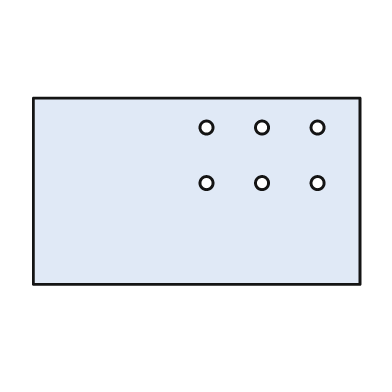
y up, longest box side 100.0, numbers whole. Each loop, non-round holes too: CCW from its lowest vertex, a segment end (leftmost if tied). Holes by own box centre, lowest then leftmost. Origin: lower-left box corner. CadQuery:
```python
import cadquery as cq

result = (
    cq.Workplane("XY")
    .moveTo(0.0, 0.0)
    .lineTo(100.0, 0.0)
    .lineTo(100.0, 57.0)
    .lineTo(0.0, 57.0)
    .close()
    .moveTo(53.0, 31.0)
    .circle(2.0)
    .moveTo(70.0, 31.0)
    .circle(2.0)
    .moveTo(87.0, 31.0)
    .circle(2.0)
    .moveTo(53.0, 48.0)
    .circle(2.0)
    .moveTo(70.0, 48.0)
    .circle(2.0)
    .moveTo(87.0, 48.0)
    .circle(2.0)
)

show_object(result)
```